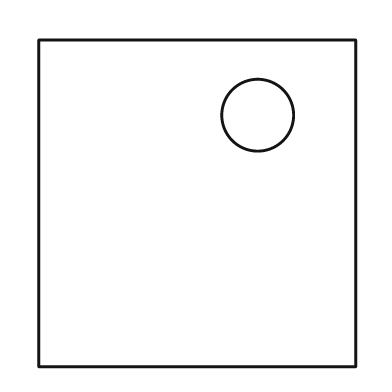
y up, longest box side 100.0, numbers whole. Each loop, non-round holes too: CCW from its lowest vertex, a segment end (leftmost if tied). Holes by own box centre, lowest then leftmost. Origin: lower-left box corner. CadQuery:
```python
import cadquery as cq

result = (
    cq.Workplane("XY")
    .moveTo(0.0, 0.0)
    .lineTo(97.0, 0.0)
    .lineTo(97.0, 100.0)
    .lineTo(0.0, 100.0)
    .close()
    .moveTo(67.0, 77.0)
    .circle(11.0)
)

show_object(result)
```